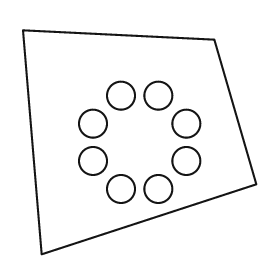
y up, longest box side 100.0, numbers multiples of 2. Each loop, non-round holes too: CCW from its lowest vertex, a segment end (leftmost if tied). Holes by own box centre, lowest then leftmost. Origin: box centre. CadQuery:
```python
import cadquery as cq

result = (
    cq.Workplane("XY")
    .moveTo(-42.0, -48.0)
    .lineTo(50.0, -18.0)
    .lineTo(32.0, 44.0)
    .lineTo(-50.0, 48.0)
    .close()
    .moveTo(-8.0, -20.0)
    .circle(6.0)
    .moveTo(8.0, -20.0)
    .circle(6.0)
    .moveTo(-20.0, -8.0)
    .circle(6.0)
    .moveTo(20.0, -8.0)
    .circle(6.0)
    .moveTo(-20.0, 8.0)
    .circle(6.0)
    .moveTo(20.0, 8.0)
    .circle(6.0)
    .moveTo(-8.0, 20.0)
    .circle(6.0)
    .moveTo(8.0, 20.0)
    .circle(6.0)
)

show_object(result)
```